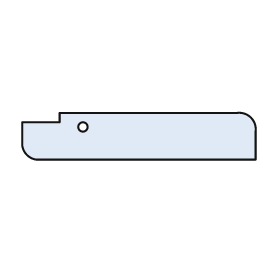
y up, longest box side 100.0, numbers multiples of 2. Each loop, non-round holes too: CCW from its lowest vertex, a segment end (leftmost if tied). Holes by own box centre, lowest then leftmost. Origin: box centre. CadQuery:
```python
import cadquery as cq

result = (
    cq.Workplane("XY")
    .moveTo(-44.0, -10.0)
    .lineTo(50.0, -10.0)
    .lineTo(50.0, 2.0)
    .threePointArc((48.0, 8.0), (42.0, 10.0))
    .lineTo(-34.0, 10.0)
    .lineTo(-34.0, 6.0)
    .lineTo(-50.0, 6.0)
    .lineTo(-50.0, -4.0)
    .threePointArc((-48.0, -8.0), (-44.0, -10.0))
    .close()
    .moveTo(-24.0, 4.0)
    .circle(2.0)
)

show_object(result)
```